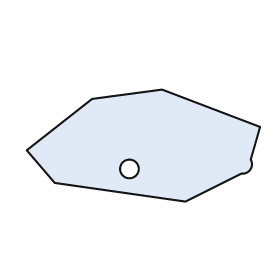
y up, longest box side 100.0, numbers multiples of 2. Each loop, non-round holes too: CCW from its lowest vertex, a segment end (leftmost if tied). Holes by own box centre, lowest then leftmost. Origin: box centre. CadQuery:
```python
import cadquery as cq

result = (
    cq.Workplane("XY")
    .moveTo(18.0, -24.0)
    .lineTo(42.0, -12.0)
    .threePointArc((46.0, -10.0), (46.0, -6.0))
    .lineTo(50.0, 8.0)
    .lineTo(8.0, 24.0)
    .lineTo(-22.0, 20.0)
    .lineTo(-50.0, -2.0)
    .lineTo(-38.0, -16.0)
    .close()
    .moveTo(-6.0, -10.0)
    .circle(4.0)
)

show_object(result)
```